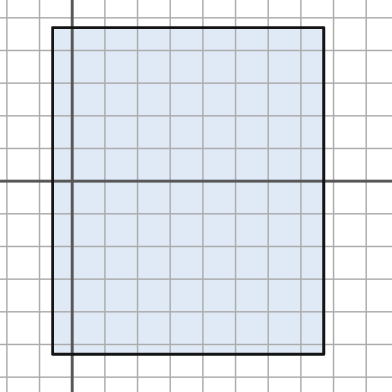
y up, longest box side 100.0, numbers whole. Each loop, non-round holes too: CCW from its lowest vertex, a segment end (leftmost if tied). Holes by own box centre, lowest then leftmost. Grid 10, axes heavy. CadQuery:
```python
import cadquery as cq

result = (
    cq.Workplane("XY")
    .moveTo(-6.0, -53.0)
    .lineTo(77.0, -53.0)
    .lineTo(77.0, 47.0)
    .lineTo(-6.0, 47.0)
    .close()
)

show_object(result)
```